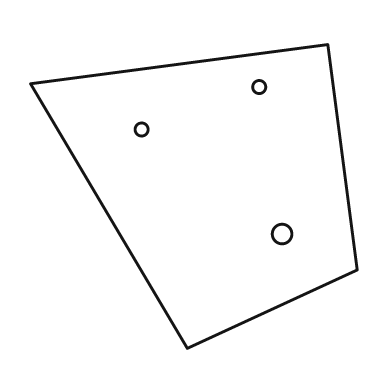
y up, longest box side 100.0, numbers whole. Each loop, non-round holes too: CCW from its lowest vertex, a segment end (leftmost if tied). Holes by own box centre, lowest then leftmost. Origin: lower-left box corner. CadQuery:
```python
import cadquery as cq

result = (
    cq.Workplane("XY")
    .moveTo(48.0, 0.0)
    .lineTo(100.0, 24.0)
    .lineTo(91.0, 93.0)
    .lineTo(0.0, 81.0)
    .close()
    .moveTo(77.0, 35.0)
    .circle(3.0)
    .moveTo(34.0, 67.0)
    .circle(2.0)
    .moveTo(70.0, 80.0)
    .circle(2.0)
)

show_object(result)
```